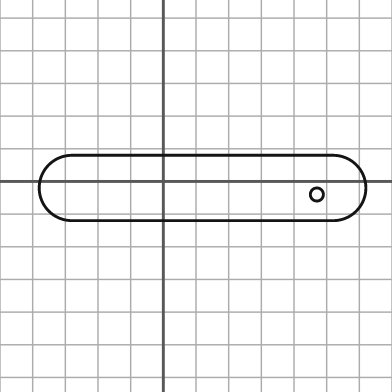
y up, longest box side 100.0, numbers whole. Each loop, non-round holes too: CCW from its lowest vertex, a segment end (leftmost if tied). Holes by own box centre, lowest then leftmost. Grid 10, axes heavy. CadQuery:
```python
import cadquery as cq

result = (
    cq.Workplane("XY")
    .moveTo(-28.0, -12.0)
    .lineTo(52.0, -12.0)
    .threePointArc((62.0, -2.0), (52.0, 8.0))
    .lineTo(-28.0, 8.0)
    .threePointArc((-38.0, -2.0), (-28.0, -12.0))
    .close()
    .moveTo(47.0, -4.0)
    .circle(2.0)
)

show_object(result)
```